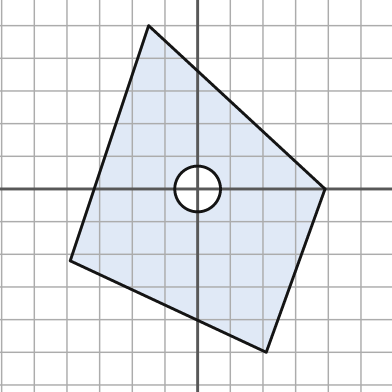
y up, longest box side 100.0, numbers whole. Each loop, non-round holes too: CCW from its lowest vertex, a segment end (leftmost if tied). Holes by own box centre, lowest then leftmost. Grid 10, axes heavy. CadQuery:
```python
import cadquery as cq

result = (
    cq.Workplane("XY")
    .moveTo(21.0, -50.0)
    .lineTo(39.0, 0.0)
    .lineTo(-15.0, 50.0)
    .lineTo(-39.0, -22.0)
    .close()
    .moveTo(0.0, 0.0)
    .circle(7.0)
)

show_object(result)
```